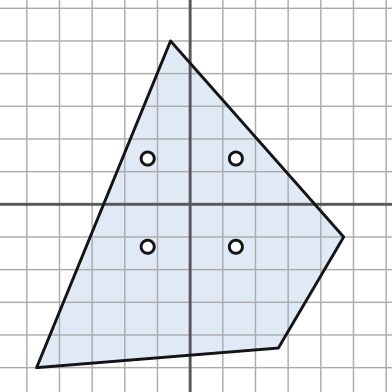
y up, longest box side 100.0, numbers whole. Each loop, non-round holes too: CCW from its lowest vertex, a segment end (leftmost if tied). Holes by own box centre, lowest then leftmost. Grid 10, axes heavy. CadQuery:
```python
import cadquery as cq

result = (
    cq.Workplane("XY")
    .moveTo(-47.0, -50.0)
    .lineTo(27.0, -44.0)
    .lineTo(47.0, -10.0)
    .lineTo(-6.0, 50.0)
    .close()
    .moveTo(-13.0, -13.0)
    .circle(2.0)
    .moveTo(14.0, -13.0)
    .circle(2.0)
    .moveTo(-13.0, 14.0)
    .circle(2.0)
    .moveTo(14.0, 14.0)
    .circle(2.0)
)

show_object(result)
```